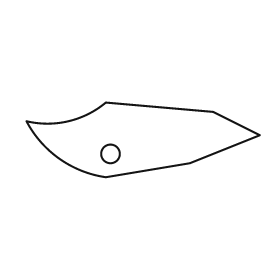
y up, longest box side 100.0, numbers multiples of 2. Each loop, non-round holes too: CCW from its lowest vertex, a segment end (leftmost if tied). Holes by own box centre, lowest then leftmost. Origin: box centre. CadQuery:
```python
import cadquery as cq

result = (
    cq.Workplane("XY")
    .moveTo(-16.0, -16.0)
    .lineTo(20.0, -10.0)
    .lineTo(50.0, 2.0)
    .lineTo(30.0, 12.0)
    .lineTo(-16.0, 16.0)
    .threePointArc((-32.0, 8.0), (-50.0, 8.0))
    .threePointArc((-36.0, -8.0), (-16.0, -16.0))
    .close()
    .moveTo(-14.0, -6.0)
    .circle(4.0)
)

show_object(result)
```